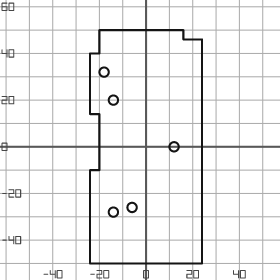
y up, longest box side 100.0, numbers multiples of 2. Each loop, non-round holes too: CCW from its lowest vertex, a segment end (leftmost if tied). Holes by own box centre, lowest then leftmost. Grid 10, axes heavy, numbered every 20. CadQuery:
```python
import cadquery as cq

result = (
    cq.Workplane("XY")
    .moveTo(-24.0, -50.0)
    .lineTo(24.0, -50.0)
    .lineTo(24.0, 46.0)
    .lineTo(16.0, 46.0)
    .lineTo(16.0, 50.0)
    .lineTo(-20.0, 50.0)
    .lineTo(-20.0, 40.0)
    .lineTo(-24.0, 40.0)
    .lineTo(-24.0, 14.0)
    .lineTo(-20.0, 14.0)
    .lineTo(-20.0, -10.0)
    .lineTo(-24.0, -10.0)
    .close()
    .moveTo(-14.0, -28.0)
    .circle(2.0)
    .moveTo(-6.0, -26.0)
    .circle(2.0)
    .moveTo(12.0, 0.0)
    .circle(2.0)
    .moveTo(-14.0, 20.0)
    .circle(2.0)
    .moveTo(-18.0, 32.0)
    .circle(2.0)
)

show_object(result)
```